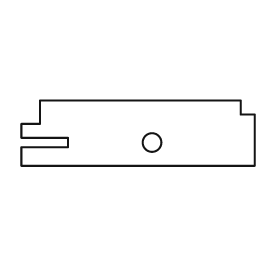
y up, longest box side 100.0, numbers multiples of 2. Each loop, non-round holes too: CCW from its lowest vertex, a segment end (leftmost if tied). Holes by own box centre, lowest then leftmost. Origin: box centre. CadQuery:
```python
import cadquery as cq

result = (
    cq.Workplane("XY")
    .moveTo(-50.0, -14.0)
    .lineTo(50.0, -14.0)
    .lineTo(50.0, 8.0)
    .lineTo(44.0, 8.0)
    .lineTo(44.0, 14.0)
    .lineTo(-42.0, 14.0)
    .lineTo(-42.0, 4.0)
    .lineTo(-50.0, 4.0)
    .lineTo(-50.0, -2.0)
    .lineTo(-30.0, -2.0)
    .lineTo(-30.0, -6.0)
    .lineTo(-50.0, -6.0)
    .close()
    .moveTo(6.0, -4.0)
    .circle(4.0)
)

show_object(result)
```